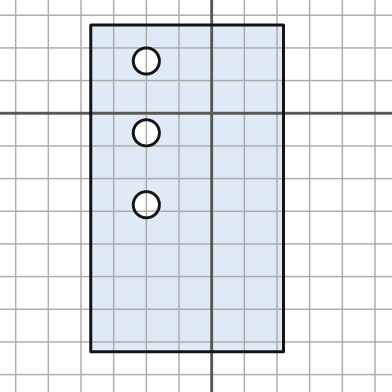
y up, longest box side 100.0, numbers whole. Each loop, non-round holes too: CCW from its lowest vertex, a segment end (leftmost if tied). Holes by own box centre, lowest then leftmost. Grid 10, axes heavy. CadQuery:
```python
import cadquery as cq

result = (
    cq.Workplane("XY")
    .moveTo(-37.0, -73.0)
    .lineTo(22.0, -73.0)
    .lineTo(22.0, 27.0)
    .lineTo(-37.0, 27.0)
    .close()
    .moveTo(-20.0, -28.0)
    .circle(4.0)
    .moveTo(-20.0, -6.0)
    .circle(4.0)
    .moveTo(-20.0, 16.0)
    .circle(4.0)
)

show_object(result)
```